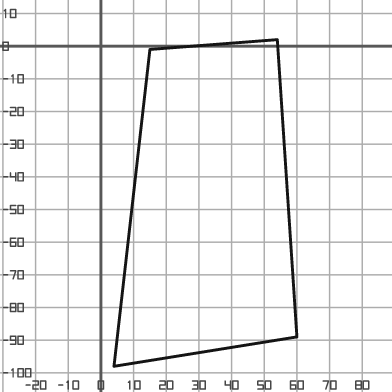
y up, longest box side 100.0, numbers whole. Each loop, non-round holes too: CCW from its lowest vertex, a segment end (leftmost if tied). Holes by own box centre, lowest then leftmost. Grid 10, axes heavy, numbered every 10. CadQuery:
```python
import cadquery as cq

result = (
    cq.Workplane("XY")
    .moveTo(4.0, -98.0)
    .lineTo(60.0, -89.0)
    .lineTo(54.0, 2.0)
    .lineTo(15.0, -1.0)
    .close()
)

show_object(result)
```